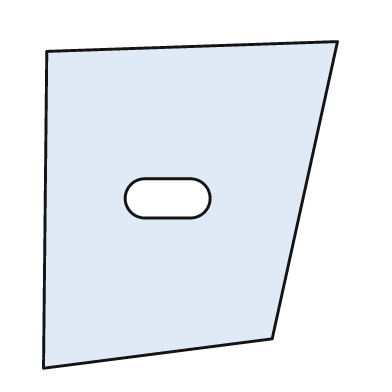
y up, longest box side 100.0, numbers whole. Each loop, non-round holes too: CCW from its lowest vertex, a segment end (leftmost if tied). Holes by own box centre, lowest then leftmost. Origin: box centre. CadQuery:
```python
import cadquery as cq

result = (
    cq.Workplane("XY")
    .moveTo(-45.0, -50.0)
    .lineTo(25.0, -41.0)
    .lineTo(45.0, 50.0)
    .lineTo(-44.0, 47.0)
    .close()
    .moveTo(-14.0, -4.0)
    .lineTo(0.0, -4.0)
    .threePointArc((6.0, 2.0), (0.0, 8.0))
    .lineTo(-14.0, 8.0)
    .threePointArc((-20.0, 2.0), (-14.0, -4.0))
    .close()
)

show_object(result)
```